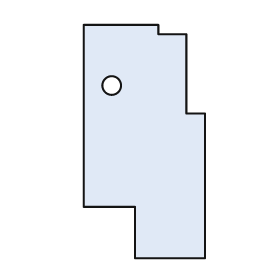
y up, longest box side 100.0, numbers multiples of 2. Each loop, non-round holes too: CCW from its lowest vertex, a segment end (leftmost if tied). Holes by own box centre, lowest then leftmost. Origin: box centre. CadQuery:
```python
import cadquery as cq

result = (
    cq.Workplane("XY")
    .moveTo(-4.0, -50.0)
    .lineTo(26.0, -50.0)
    .lineTo(26.0, 12.0)
    .lineTo(18.0, 12.0)
    .lineTo(18.0, 46.0)
    .lineTo(6.0, 46.0)
    .lineTo(6.0, 50.0)
    .lineTo(-26.0, 50.0)
    .lineTo(-26.0, -28.0)
    .lineTo(-4.0, -28.0)
    .close()
    .moveTo(-14.0, 24.0)
    .circle(4.0)
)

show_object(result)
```